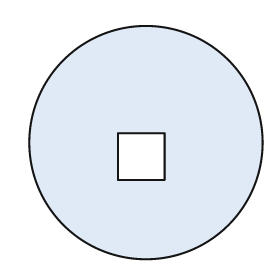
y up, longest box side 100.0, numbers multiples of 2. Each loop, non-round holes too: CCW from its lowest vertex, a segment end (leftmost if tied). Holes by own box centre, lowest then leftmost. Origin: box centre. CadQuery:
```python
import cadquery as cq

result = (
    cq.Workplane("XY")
    .moveTo(0.0, 0.0)
    .circle(50.0)
    .moveTo(-12.0, -16.0)
    .lineTo(8.0, -16.0)
    .lineTo(8.0, 4.0)
    .lineTo(-12.0, 4.0)
    .close()
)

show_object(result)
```